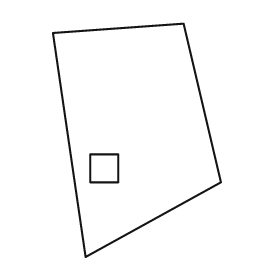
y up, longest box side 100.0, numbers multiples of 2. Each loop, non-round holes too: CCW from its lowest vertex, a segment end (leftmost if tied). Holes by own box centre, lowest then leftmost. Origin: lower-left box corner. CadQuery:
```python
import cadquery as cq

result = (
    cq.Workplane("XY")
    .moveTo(14.0, 0.0)
    .lineTo(72.0, 32.0)
    .lineTo(56.0, 100.0)
    .lineTo(0.0, 96.0)
    .close()
    .moveTo(16.0, 32.0)
    .lineTo(28.0, 32.0)
    .lineTo(28.0, 44.0)
    .lineTo(16.0, 44.0)
    .close()
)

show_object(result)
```